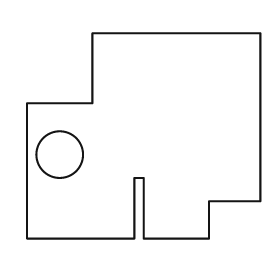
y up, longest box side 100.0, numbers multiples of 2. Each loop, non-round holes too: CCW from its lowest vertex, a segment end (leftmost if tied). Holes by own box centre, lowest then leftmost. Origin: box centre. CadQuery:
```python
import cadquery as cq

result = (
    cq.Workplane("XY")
    .moveTo(-50.0, -44.0)
    .lineTo(-4.0, -44.0)
    .lineTo(-4.0, -18.0)
    .lineTo(0.0, -18.0)
    .lineTo(0.0, -44.0)
    .lineTo(28.0, -44.0)
    .lineTo(28.0, -28.0)
    .lineTo(50.0, -28.0)
    .lineTo(50.0, 44.0)
    .lineTo(-22.0, 44.0)
    .lineTo(-22.0, 14.0)
    .lineTo(-50.0, 14.0)
    .close()
    .moveTo(-36.0, -8.0)
    .circle(10.0)
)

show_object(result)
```